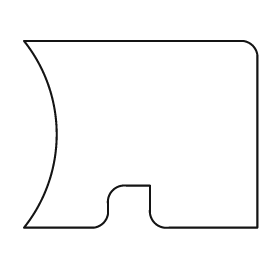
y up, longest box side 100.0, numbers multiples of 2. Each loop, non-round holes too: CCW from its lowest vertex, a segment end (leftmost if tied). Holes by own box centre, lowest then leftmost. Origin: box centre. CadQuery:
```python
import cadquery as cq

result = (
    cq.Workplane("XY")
    .moveTo(-50.0, -40.0)
    .lineTo(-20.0, -40.0)
    .threePointArc((-16.0, -38.0), (-14.0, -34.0))
    .lineTo(-14.0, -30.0)
    .threePointArc((-12.0, -24.0), (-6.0, -22.0))
    .lineTo(4.0, -22.0)
    .lineTo(4.0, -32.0)
    .threePointArc((6.0, -38.0), (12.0, -40.0))
    .lineTo(50.0, -40.0)
    .lineTo(50.0, 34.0)
    .threePointArc((48.0, 38.0), (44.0, 40.0))
    .lineTo(-50.0, 40.0)
    .threePointArc((-36.0, 0.0), (-50.0, -40.0))
    .close()
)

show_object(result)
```